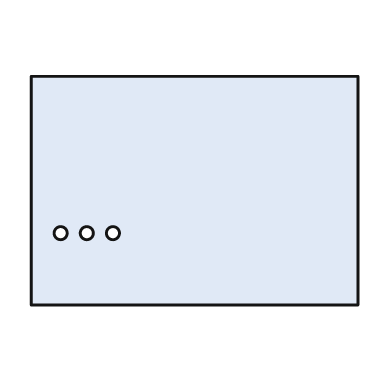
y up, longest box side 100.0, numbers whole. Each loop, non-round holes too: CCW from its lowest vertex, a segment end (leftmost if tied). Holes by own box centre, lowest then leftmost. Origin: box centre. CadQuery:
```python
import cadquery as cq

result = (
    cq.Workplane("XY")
    .moveTo(-50.0, -35.0)
    .lineTo(50.0, -35.0)
    .lineTo(50.0, 35.0)
    .lineTo(-50.0, 35.0)
    .close()
    .moveTo(-41.0, -13.0)
    .circle(2.0)
    .moveTo(-33.0, -13.0)
    .circle(2.0)
    .moveTo(-25.0, -13.0)
    .circle(2.0)
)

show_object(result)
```